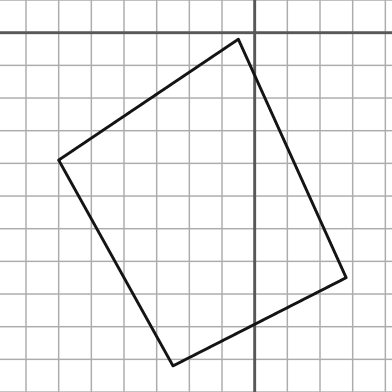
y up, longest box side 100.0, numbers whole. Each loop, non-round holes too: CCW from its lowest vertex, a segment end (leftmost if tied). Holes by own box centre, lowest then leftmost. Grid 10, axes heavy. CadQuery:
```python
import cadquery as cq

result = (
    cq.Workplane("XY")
    .moveTo(-25.0, -102.0)
    .lineTo(28.0, -75.0)
    .lineTo(-5.0, -2.0)
    .lineTo(-60.0, -39.0)
    .close()
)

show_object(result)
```